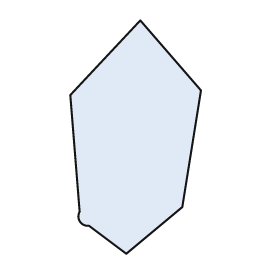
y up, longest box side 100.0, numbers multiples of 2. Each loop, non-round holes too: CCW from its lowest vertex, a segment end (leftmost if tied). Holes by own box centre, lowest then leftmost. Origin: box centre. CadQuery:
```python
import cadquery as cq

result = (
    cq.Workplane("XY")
    .moveTo(-4.0, -50.0)
    .lineTo(20.0, -30.0)
    .lineTo(28.0, 20.0)
    .lineTo(2.0, 50.0)
    .lineTo(-28.0, 18.0)
    .lineTo(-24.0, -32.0)
    .threePointArc((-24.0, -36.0), (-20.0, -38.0))
    .close()
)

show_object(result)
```